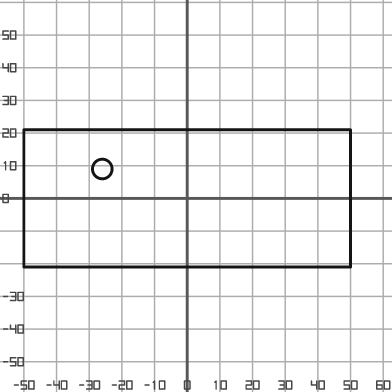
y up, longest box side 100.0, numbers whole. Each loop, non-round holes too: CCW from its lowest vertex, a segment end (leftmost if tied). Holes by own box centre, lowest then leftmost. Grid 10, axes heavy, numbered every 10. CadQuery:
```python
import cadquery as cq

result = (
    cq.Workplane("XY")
    .moveTo(-50.0, -21.0)
    .lineTo(50.0, -21.0)
    .lineTo(50.0, 21.0)
    .lineTo(-50.0, 21.0)
    .close()
    .moveTo(-26.0, 9.0)
    .circle(3.0)
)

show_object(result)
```